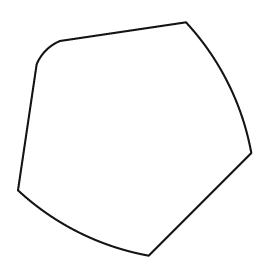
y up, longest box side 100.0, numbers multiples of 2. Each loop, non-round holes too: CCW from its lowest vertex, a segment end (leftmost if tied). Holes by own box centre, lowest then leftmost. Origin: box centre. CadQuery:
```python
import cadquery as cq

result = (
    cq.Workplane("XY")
    .moveTo(6.0, -50.0)
    .lineTo(50.0, -6.0)
    .threePointArc((40.0, 24.0), (22.0, 50.0))
    .lineTo(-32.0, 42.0)
    .threePointArc((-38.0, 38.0), (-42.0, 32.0))
    .lineTo(-50.0, -22.0)
    .threePointArc((-24.0, -40.0), (6.0, -50.0))
    .close()
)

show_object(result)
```